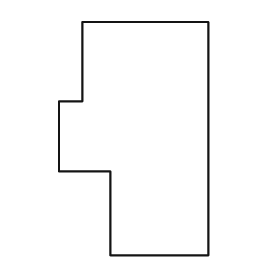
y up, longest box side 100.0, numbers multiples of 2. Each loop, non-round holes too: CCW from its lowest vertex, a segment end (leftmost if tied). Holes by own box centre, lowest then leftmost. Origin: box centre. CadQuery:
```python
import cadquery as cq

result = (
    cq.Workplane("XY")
    .moveTo(-10.0, -50.0)
    .lineTo(32.0, -50.0)
    .lineTo(32.0, 50.0)
    .lineTo(-22.0, 50.0)
    .lineTo(-22.0, 16.0)
    .lineTo(-32.0, 16.0)
    .lineTo(-32.0, -14.0)
    .lineTo(-10.0, -14.0)
    .close()
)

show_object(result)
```